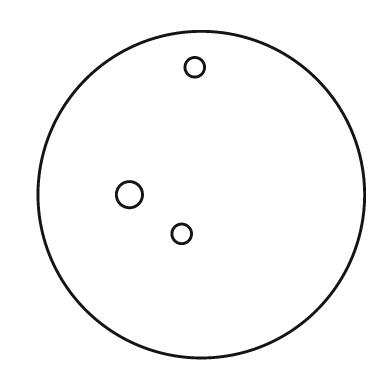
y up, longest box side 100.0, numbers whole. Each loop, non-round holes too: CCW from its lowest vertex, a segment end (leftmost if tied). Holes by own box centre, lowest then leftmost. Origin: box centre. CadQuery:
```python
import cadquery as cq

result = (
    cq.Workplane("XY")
    .moveTo(0.0, 0.0)
    .circle(50.0)
    .moveTo(-6.0, -12.0)
    .circle(3.0)
    .moveTo(-22.0, 0.0)
    .circle(4.0)
    .moveTo(-2.0, 39.0)
    .circle(3.0)
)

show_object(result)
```